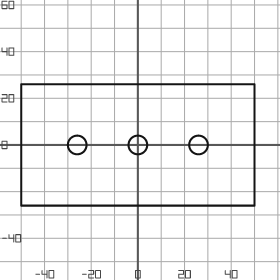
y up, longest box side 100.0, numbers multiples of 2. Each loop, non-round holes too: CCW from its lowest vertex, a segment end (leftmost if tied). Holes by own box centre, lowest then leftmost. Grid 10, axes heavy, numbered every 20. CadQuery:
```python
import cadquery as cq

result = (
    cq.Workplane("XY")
    .moveTo(-50.0, -26.0)
    .lineTo(50.0, -26.0)
    .lineTo(50.0, 26.0)
    .lineTo(-50.0, 26.0)
    .close()
    .moveTo(-26.0, 0.0)
    .circle(4.0)
    .moveTo(0.0, 0.0)
    .circle(4.0)
    .moveTo(26.0, 0.0)
    .circle(4.0)
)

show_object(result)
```